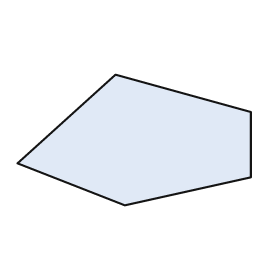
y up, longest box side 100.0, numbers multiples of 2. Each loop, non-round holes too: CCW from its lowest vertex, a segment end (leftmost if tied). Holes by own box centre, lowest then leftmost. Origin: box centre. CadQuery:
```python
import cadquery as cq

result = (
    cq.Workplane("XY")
    .moveTo(-4.0, -28.0)
    .lineTo(50.0, -16.0)
    .lineTo(50.0, 12.0)
    .lineTo(-8.0, 28.0)
    .lineTo(-50.0, -10.0)
    .close()
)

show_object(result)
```